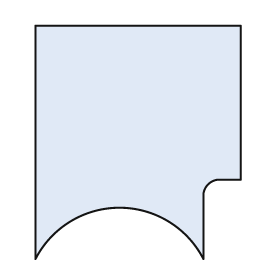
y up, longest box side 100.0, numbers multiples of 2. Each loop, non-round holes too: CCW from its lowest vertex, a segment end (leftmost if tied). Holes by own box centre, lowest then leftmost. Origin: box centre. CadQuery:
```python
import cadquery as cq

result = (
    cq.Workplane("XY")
    .moveTo(-44.0, -50.0)
    .threePointArc((-8.0, -28.0), (28.0, -50.0))
    .lineTo(28.0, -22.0)
    .threePointArc((30.0, -18.0), (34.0, -16.0))
    .lineTo(44.0, -16.0)
    .lineTo(44.0, 50.0)
    .lineTo(-44.0, 50.0)
    .close()
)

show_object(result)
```